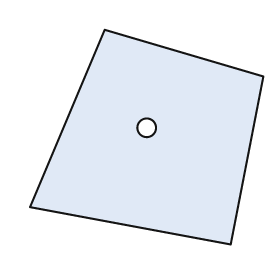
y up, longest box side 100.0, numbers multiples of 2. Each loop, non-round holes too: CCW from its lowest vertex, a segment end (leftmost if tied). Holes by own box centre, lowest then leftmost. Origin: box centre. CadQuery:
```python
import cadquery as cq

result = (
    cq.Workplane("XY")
    .moveTo(36.0, -46.0)
    .lineTo(50.0, 26.0)
    .lineTo(-18.0, 46.0)
    .lineTo(-50.0, -30.0)
    .close()
    .moveTo(0.0, 4.0)
    .circle(4.0)
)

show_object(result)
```